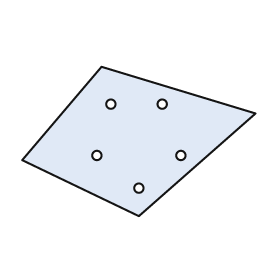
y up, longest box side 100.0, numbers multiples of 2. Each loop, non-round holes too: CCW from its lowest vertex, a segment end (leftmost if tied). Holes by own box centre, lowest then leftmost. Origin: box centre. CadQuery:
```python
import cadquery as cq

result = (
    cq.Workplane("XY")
    .moveTo(0.0, -32.0)
    .lineTo(50.0, 12.0)
    .lineTo(-16.0, 32.0)
    .lineTo(-50.0, -8.0)
    .close()
    .moveTo(0.0, -20.0)
    .circle(2.0)
    .moveTo(-18.0, -6.0)
    .circle(2.0)
    .moveTo(18.0, -6.0)
    .circle(2.0)
    .moveTo(-12.0, 16.0)
    .circle(2.0)
    .moveTo(10.0, 16.0)
    .circle(2.0)
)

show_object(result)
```